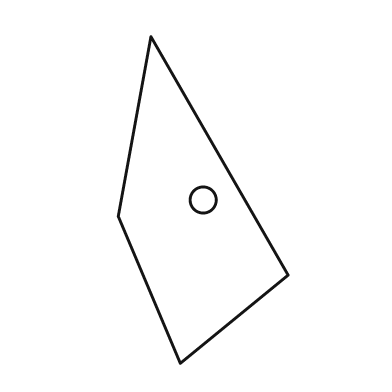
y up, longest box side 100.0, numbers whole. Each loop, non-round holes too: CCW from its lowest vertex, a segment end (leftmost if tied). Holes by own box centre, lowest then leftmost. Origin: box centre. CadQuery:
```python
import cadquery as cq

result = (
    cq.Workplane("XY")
    .moveTo(-7.0, -50.0)
    .lineTo(26.0, -23.0)
    .lineTo(-16.0, 50.0)
    .lineTo(-26.0, -5.0)
    .close()
    .moveTo(0.0, 0.0)
    .circle(4.0)
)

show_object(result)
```